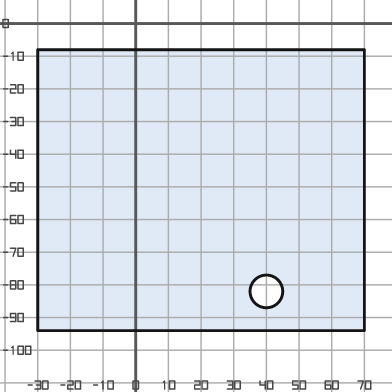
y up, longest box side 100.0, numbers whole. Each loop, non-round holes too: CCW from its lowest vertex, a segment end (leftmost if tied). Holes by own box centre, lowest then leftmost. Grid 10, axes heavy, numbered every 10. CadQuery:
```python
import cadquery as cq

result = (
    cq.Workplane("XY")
    .moveTo(-30.0, -94.0)
    .lineTo(70.0, -94.0)
    .lineTo(70.0, -8.0)
    .lineTo(-30.0, -8.0)
    .close()
    .moveTo(40.0, -82.0)
    .circle(5.0)
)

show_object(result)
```